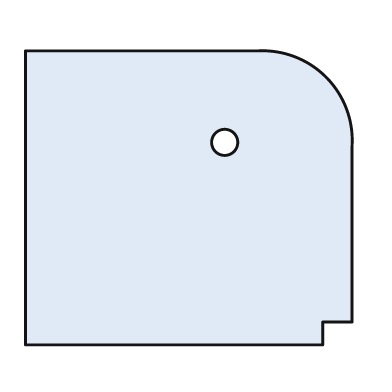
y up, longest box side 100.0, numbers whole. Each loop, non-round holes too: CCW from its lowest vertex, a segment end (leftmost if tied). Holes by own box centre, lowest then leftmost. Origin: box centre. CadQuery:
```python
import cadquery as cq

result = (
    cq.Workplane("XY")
    .moveTo(-50.0, -45.0)
    .lineTo(41.0, -45.0)
    .lineTo(41.0, -38.0)
    .lineTo(50.0, -38.0)
    .lineTo(50.0, 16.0)
    .threePointArc((42.0, 37.0), (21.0, 45.0))
    .lineTo(-50.0, 45.0)
    .close()
    .moveTo(11.0, 17.0)
    .circle(4.0)
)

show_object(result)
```